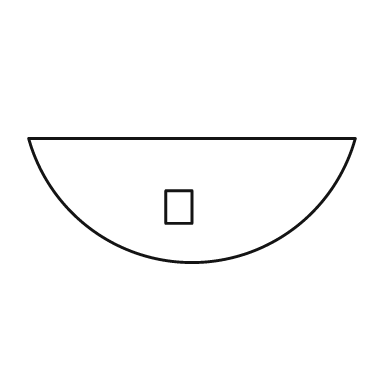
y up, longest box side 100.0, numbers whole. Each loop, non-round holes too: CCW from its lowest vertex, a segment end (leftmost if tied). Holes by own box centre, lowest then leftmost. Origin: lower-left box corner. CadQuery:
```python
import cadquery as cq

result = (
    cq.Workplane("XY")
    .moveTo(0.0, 38.0)
    .threePointArc((50.0, 0.0), (100.0, 38.0))
    .close()
    .moveTo(42.0, 12.0)
    .lineTo(50.0, 12.0)
    .lineTo(50.0, 22.0)
    .lineTo(42.0, 22.0)
    .close()
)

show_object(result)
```